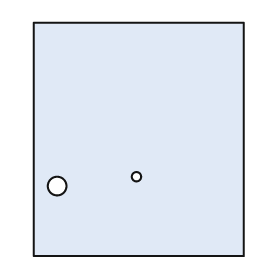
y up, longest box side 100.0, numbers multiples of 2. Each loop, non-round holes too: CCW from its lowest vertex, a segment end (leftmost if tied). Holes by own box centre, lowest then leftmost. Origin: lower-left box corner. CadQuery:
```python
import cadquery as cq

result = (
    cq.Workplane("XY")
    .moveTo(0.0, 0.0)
    .lineTo(90.0, 0.0)
    .lineTo(90.0, 100.0)
    .lineTo(0.0, 100.0)
    .close()
    .moveTo(10.0, 30.0)
    .circle(4.0)
    .moveTo(44.0, 34.0)
    .circle(2.0)
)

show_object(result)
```